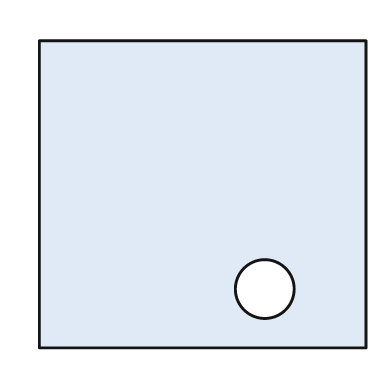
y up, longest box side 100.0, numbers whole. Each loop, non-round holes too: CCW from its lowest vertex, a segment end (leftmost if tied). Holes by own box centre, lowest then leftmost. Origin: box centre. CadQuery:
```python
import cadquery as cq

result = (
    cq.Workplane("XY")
    .moveTo(-50.0, -47.0)
    .lineTo(50.0, -47.0)
    .lineTo(50.0, 47.0)
    .lineTo(-50.0, 47.0)
    .close()
    .moveTo(19.0, -29.0)
    .circle(9.0)
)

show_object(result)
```